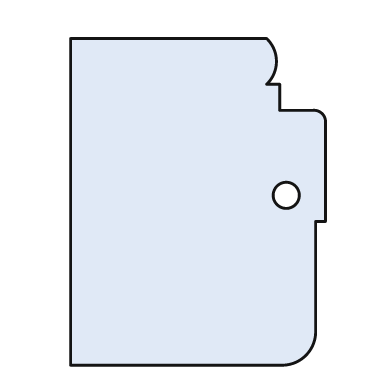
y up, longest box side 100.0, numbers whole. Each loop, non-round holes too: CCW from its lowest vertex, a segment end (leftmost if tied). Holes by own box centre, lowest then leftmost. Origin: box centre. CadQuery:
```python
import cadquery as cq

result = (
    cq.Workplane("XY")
    .moveTo(-39.0, -50.0)
    .lineTo(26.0, -50.0)
    .threePointArc((33.0, -47.0), (36.0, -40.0))
    .lineTo(36.0, -6.0)
    .lineTo(39.0, -6.0)
    .lineTo(39.0, 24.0)
    .threePointArc((38.0, 27.0), (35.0, 28.0))
    .lineTo(25.0, 28.0)
    .lineTo(25.0, 36.0)
    .lineTo(21.0, 36.0)
    .threePointArc((24.0, 43.0), (21.0, 50.0))
    .lineTo(-39.0, 50.0)
    .close()
    .moveTo(27.0, 2.0)
    .circle(4.0)
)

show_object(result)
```